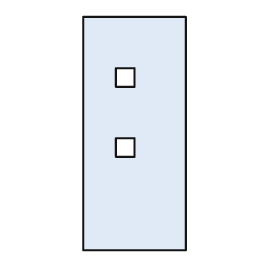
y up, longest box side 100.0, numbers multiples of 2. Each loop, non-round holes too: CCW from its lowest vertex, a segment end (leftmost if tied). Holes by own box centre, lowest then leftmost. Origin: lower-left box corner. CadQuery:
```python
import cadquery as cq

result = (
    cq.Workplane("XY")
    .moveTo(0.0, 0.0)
    .lineTo(44.0, 0.0)
    .lineTo(44.0, 100.0)
    .lineTo(0.0, 100.0)
    .close()
    .moveTo(14.0, 40.0)
    .lineTo(22.0, 40.0)
    .lineTo(22.0, 48.0)
    .lineTo(14.0, 48.0)
    .close()
    .moveTo(14.0, 70.0)
    .lineTo(22.0, 70.0)
    .lineTo(22.0, 78.0)
    .lineTo(14.0, 78.0)
    .close()
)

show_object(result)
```